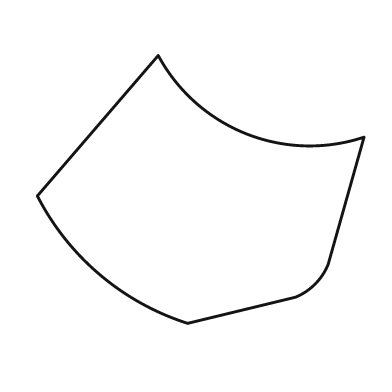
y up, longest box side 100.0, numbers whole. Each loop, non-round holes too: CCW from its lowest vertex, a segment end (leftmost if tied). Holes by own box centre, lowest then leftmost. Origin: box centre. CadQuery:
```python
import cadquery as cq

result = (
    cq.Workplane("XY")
    .moveTo(-4.0, -41.0)
    .lineTo(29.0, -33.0)
    .threePointArc((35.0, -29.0), (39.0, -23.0))
    .lineTo(50.0, 16.0)
    .threePointArc((14.0, 17.0), (-13.0, 41.0))
    .lineTo(-50.0, -2.0)
    .threePointArc((-31.0, -26.0), (-4.0, -41.0))
    .close()
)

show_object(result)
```